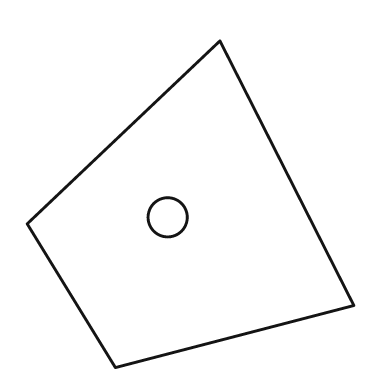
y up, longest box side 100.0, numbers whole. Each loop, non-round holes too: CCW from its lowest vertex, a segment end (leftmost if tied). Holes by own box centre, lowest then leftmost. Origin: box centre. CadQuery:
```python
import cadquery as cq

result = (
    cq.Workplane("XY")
    .moveTo(-23.0, -50.0)
    .lineTo(50.0, -31.0)
    .lineTo(9.0, 50.0)
    .lineTo(-50.0, -6.0)
    .close()
    .moveTo(-7.0, -4.0)
    .circle(6.0)
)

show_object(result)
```